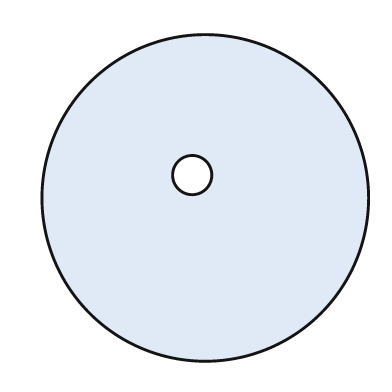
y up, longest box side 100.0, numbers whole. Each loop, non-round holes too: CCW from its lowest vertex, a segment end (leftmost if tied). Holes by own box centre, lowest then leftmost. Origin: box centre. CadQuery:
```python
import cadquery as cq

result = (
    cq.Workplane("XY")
    .moveTo(0.0, 0.0)
    .circle(50.0)
    .moveTo(-4.0, 7.0)
    .circle(6.0)
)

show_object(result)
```